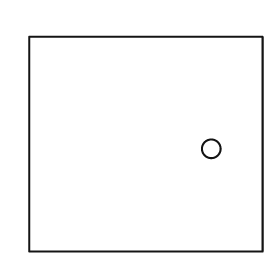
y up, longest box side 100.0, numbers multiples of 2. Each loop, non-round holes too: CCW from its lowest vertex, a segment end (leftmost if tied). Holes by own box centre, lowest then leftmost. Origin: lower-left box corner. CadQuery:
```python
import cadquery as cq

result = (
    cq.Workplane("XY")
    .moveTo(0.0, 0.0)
    .lineTo(100.0, 0.0)
    .lineTo(100.0, 92.0)
    .lineTo(0.0, 92.0)
    .close()
    .moveTo(78.0, 44.0)
    .circle(4.0)
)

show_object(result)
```